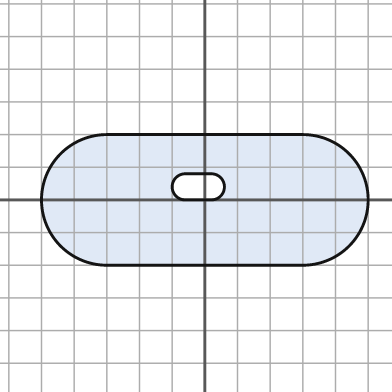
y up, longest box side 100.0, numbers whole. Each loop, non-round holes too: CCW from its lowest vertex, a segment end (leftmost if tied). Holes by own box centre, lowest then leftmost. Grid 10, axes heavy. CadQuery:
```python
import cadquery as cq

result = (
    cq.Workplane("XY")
    .moveTo(-30.0, -20.0)
    .lineTo(30.0, -20.0)
    .threePointArc((50.0, 0.0), (30.0, 20.0))
    .lineTo(-30.0, 20.0)
    .threePointArc((-50.0, 0.0), (-30.0, -20.0))
    .close()
    .moveTo(-6.0, 0.0)
    .lineTo(2.0, 0.0)
    .threePointArc((6.0, 4.0), (2.0, 8.0))
    .lineTo(-6.0, 8.0)
    .threePointArc((-10.0, 4.0), (-6.0, 0.0))
    .close()
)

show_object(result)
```